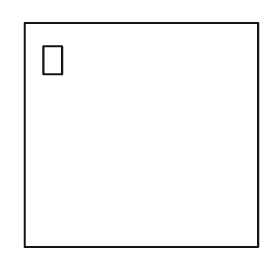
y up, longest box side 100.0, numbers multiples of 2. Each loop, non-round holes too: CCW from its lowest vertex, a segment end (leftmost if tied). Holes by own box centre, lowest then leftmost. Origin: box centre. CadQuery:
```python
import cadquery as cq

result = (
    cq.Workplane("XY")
    .moveTo(-50.0, -48.0)
    .lineTo(50.0, -48.0)
    .lineTo(50.0, 48.0)
    .lineTo(-50.0, 48.0)
    .close()
    .moveTo(-42.0, 26.0)
    .lineTo(-34.0, 26.0)
    .lineTo(-34.0, 38.0)
    .lineTo(-42.0, 38.0)
    .close()
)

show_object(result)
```